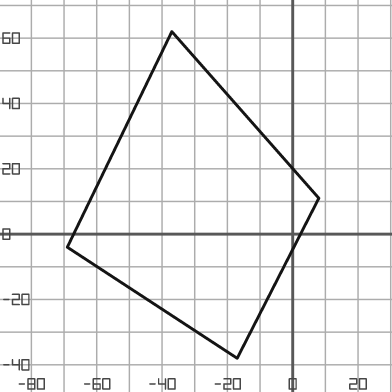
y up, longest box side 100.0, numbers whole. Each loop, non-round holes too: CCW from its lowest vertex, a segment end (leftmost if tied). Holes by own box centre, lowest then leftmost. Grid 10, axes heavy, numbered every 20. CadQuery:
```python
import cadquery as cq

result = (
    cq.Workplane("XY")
    .moveTo(-17.0, -38.0)
    .lineTo(8.0, 11.0)
    .lineTo(-37.0, 62.0)
    .lineTo(-69.0, -4.0)
    .close()
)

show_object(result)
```